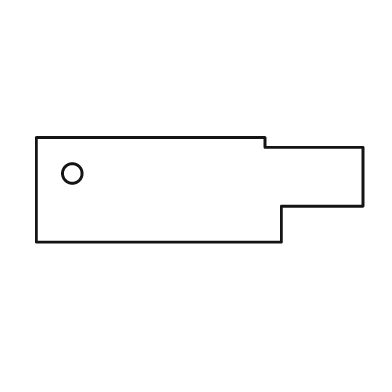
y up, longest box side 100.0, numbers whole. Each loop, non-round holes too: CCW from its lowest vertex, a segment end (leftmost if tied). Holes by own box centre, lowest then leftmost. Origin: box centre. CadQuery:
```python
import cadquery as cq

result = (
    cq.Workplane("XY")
    .moveTo(-50.0, -16.0)
    .lineTo(25.0, -16.0)
    .lineTo(25.0, -5.0)
    .lineTo(50.0, -5.0)
    .lineTo(50.0, 13.0)
    .lineTo(20.0, 13.0)
    .lineTo(20.0, 16.0)
    .lineTo(-50.0, 16.0)
    .close()
    .moveTo(-39.0, 5.0)
    .circle(3.0)
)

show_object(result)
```